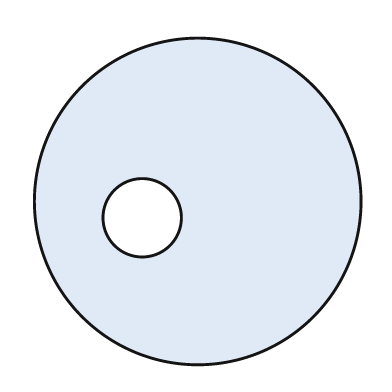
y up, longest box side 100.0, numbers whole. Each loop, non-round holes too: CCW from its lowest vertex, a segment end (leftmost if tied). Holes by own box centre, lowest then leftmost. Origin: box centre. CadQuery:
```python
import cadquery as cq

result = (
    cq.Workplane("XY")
    .moveTo(0.0, 0.0)
    .circle(50.0)
    .moveTo(-17.0, -5.0)
    .circle(12.0)
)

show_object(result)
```